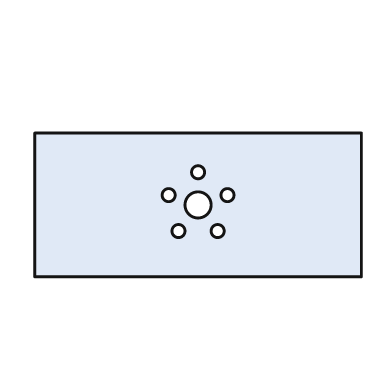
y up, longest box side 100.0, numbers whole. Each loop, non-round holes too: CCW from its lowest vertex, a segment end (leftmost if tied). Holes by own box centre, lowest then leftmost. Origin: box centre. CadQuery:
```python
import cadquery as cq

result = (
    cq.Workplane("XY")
    .moveTo(-50.0, -22.0)
    .lineTo(50.0, -22.0)
    .lineTo(50.0, 22.0)
    .lineTo(-50.0, 22.0)
    .close()
    .moveTo(-6.0, -8.0)
    .circle(2.0)
    .moveTo(6.0, -8.0)
    .circle(2.0)
    .moveTo(0.0, 0.0)
    .circle(4.0)
    .moveTo(-9.0, 3.0)
    .circle(2.0)
    .moveTo(9.0, 3.0)
    .circle(2.0)
    .moveTo(0.0, 10.0)
    .circle(2.0)
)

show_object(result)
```